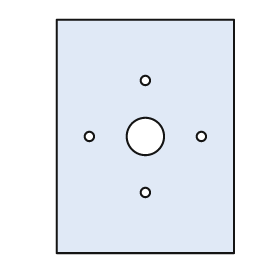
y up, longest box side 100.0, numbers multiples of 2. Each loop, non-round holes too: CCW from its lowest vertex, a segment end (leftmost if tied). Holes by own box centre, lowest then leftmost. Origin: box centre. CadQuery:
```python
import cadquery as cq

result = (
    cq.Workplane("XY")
    .moveTo(-38.0, -50.0)
    .lineTo(38.0, -50.0)
    .lineTo(38.0, 50.0)
    .lineTo(-38.0, 50.0)
    .close()
    .moveTo(0.0, -24.0)
    .circle(2.0)
    .moveTo(-24.0, 0.0)
    .circle(2.0)
    .moveTo(0.0, 0.0)
    .circle(8.0)
    .moveTo(24.0, 0.0)
    .circle(2.0)
    .moveTo(0.0, 24.0)
    .circle(2.0)
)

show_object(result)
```